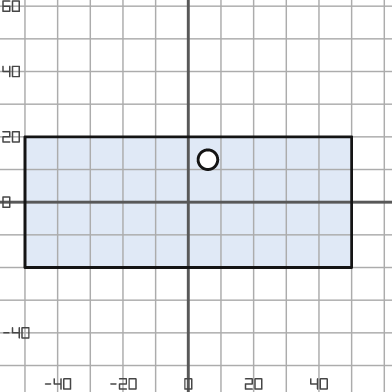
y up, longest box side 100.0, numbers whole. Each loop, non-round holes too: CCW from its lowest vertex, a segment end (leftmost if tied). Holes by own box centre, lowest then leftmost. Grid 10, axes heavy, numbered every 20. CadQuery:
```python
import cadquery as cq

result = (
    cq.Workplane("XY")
    .moveTo(-50.0, -20.0)
    .lineTo(50.0, -20.0)
    .lineTo(50.0, 20.0)
    .lineTo(-50.0, 20.0)
    .close()
    .moveTo(6.0, 13.0)
    .circle(3.0)
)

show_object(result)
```